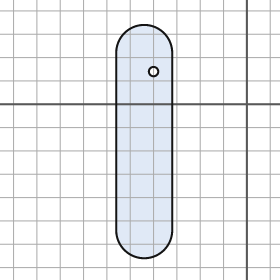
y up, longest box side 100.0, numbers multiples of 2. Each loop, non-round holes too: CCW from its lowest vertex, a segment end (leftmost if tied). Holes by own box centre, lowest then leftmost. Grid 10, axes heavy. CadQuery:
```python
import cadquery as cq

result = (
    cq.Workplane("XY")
    .moveTo(-56.0, -54.0)
    .threePointArc((-44.0, -66.0), (-32.0, -54.0))
    .lineTo(-32.0, 22.0)
    .threePointArc((-44.0, 34.0), (-56.0, 22.0))
    .close()
    .moveTo(-40.0, 14.0)
    .circle(2.0)
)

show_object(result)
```